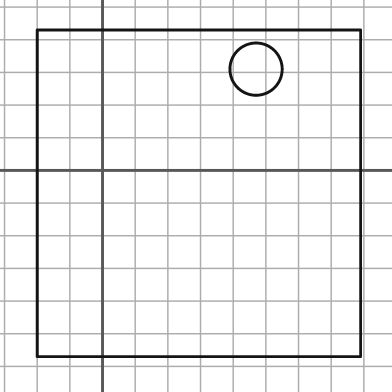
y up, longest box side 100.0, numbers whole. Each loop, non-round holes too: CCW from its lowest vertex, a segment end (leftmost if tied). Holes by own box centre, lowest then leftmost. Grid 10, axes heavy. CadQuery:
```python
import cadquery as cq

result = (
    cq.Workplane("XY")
    .moveTo(-20.0, -57.0)
    .lineTo(79.0, -57.0)
    .lineTo(79.0, 43.0)
    .lineTo(-20.0, 43.0)
    .close()
    .moveTo(47.0, 31.0)
    .circle(8.0)
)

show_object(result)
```